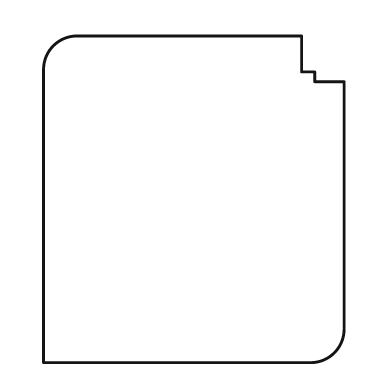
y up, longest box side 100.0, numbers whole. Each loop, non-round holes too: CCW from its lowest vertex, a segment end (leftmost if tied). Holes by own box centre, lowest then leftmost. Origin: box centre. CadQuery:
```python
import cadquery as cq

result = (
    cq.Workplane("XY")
    .moveTo(-46.0, -50.0)
    .lineTo(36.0, -50.0)
    .threePointArc((43.0, -47.0), (46.0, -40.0))
    .lineTo(46.0, 36.0)
    .lineTo(37.0, 36.0)
    .lineTo(37.0, 39.0)
    .lineTo(33.0, 39.0)
    .lineTo(33.0, 50.0)
    .lineTo(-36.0, 50.0)
    .threePointArc((-43.0, 47.0), (-46.0, 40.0))
    .close()
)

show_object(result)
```